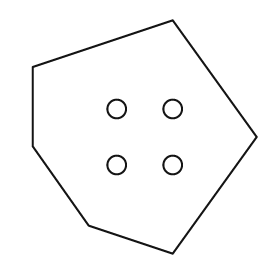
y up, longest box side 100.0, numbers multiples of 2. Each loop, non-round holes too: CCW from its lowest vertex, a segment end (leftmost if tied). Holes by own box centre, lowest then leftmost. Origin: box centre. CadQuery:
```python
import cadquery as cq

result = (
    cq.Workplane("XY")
    .moveTo(12.0, -50.0)
    .lineTo(48.0, 0.0)
    .lineTo(12.0, 50.0)
    .lineTo(-48.0, 30.0)
    .lineTo(-48.0, -4.0)
    .lineTo(-24.0, -38.0)
    .close()
    .moveTo(-12.0, -12.0)
    .circle(4.0)
    .moveTo(12.0, -12.0)
    .circle(4.0)
    .moveTo(-12.0, 12.0)
    .circle(4.0)
    .moveTo(12.0, 12.0)
    .circle(4.0)
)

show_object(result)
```